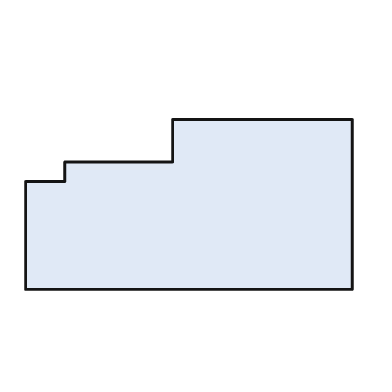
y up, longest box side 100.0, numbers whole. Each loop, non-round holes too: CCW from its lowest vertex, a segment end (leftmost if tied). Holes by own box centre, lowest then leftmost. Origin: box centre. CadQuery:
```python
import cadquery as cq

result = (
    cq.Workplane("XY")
    .moveTo(-50.0, -26.0)
    .lineTo(50.0, -26.0)
    .lineTo(50.0, 26.0)
    .lineTo(-5.0, 26.0)
    .lineTo(-5.0, 13.0)
    .lineTo(-38.0, 13.0)
    .lineTo(-38.0, 7.0)
    .lineTo(-50.0, 7.0)
    .close()
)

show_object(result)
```